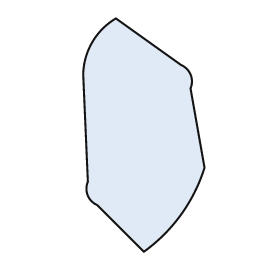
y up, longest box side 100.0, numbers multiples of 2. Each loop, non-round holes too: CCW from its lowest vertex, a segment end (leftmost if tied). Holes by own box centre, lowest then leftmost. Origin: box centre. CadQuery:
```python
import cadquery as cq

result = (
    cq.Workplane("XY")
    .moveTo(0.0, -50.0)
    .threePointArc((16.0, -34.0), (26.0, -14.0))
    .lineTo(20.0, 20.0)
    .threePointArc((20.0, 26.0), (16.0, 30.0))
    .lineTo(-12.0, 50.0)
    .threePointArc((-22.0, 40.0), (-26.0, 26.0))
    .lineTo(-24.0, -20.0)
    .threePointArc((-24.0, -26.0), (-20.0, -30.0))
    .close()
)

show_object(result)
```